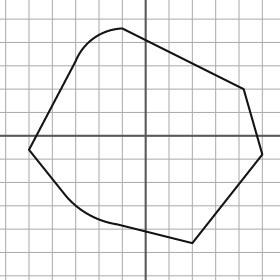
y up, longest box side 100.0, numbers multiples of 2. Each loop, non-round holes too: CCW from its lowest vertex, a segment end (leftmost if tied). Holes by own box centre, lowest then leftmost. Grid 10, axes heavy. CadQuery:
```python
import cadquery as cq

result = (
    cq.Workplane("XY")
    .moveTo(20.0, -46.0)
    .lineTo(50.0, -8.0)
    .lineTo(42.0, 20.0)
    .lineTo(-10.0, 46.0)
    .threePointArc((-22.0, 42.0), (-30.0, 32.0))
    .lineTo(-50.0, -6.0)
    .lineTo(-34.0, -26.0)
    .threePointArc((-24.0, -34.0), (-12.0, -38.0))
    .close()
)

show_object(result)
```